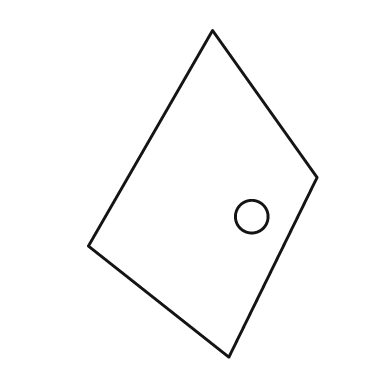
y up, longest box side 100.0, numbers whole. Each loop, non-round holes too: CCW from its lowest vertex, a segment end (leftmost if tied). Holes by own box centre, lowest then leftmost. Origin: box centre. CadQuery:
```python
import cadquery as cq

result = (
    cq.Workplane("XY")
    .moveTo(8.0, -50.0)
    .lineTo(35.0, 5.0)
    .lineTo(3.0, 50.0)
    .lineTo(-35.0, -16.0)
    .close()
    .moveTo(15.0, -7.0)
    .circle(5.0)
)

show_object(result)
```